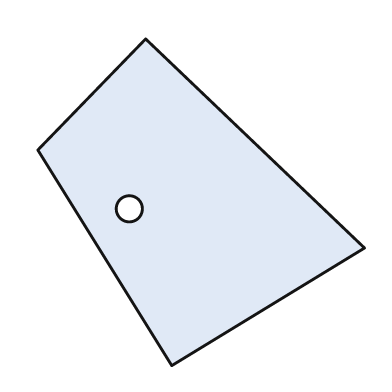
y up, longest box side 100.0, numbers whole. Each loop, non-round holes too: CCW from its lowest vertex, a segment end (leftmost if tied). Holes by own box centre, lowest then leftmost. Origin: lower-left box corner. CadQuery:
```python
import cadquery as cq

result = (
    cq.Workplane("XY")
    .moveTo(41.0, 0.0)
    .lineTo(100.0, 36.0)
    .lineTo(33.0, 100.0)
    .lineTo(0.0, 66.0)
    .close()
    .moveTo(28.0, 48.0)
    .circle(4.0)
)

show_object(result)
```